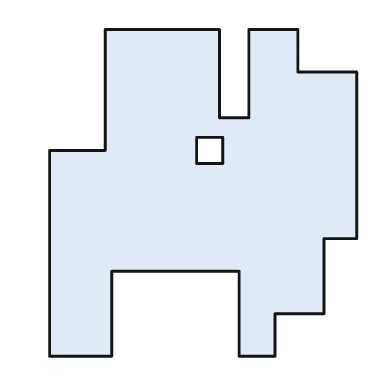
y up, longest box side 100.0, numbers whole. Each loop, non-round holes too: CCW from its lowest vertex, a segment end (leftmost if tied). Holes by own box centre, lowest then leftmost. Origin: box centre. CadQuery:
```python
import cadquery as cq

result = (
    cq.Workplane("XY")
    .moveTo(-47.0, -50.0)
    .lineTo(-28.0, -50.0)
    .lineTo(-28.0, -24.0)
    .lineTo(11.0, -24.0)
    .lineTo(11.0, -50.0)
    .lineTo(22.0, -50.0)
    .lineTo(22.0, -37.0)
    .lineTo(37.0, -37.0)
    .lineTo(37.0, -14.0)
    .lineTo(47.0, -14.0)
    .lineTo(47.0, 37.0)
    .lineTo(29.0, 37.0)
    .lineTo(29.0, 50.0)
    .lineTo(14.0, 50.0)
    .lineTo(14.0, 23.0)
    .lineTo(5.0, 23.0)
    .lineTo(5.0, 50.0)
    .lineTo(-30.0, 50.0)
    .lineTo(-30.0, 13.0)
    .lineTo(-47.0, 13.0)
    .close()
    .moveTo(-2.0, 9.0)
    .lineTo(6.0, 9.0)
    .lineTo(6.0, 17.0)
    .lineTo(-2.0, 17.0)
    .close()
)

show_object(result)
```